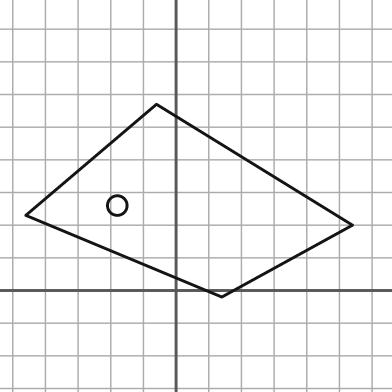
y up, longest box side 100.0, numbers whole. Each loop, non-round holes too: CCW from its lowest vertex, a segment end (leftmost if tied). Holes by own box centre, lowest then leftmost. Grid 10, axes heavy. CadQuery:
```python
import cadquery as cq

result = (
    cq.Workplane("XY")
    .moveTo(14.0, -2.0)
    .lineTo(54.0, 20.0)
    .lineTo(-6.0, 57.0)
    .lineTo(-46.0, 23.0)
    .close()
    .moveTo(-18.0, 26.0)
    .circle(3.0)
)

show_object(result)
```